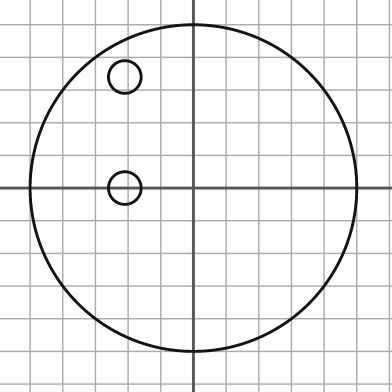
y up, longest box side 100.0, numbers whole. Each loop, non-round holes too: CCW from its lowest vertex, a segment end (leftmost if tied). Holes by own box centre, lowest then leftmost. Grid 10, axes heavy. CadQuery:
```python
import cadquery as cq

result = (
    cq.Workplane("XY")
    .moveTo(0.0, 0.0)
    .circle(50.0)
    .moveTo(-21.0, 0.0)
    .circle(5.0)
    .moveTo(-21.0, 34.0)
    .circle(5.0)
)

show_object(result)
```